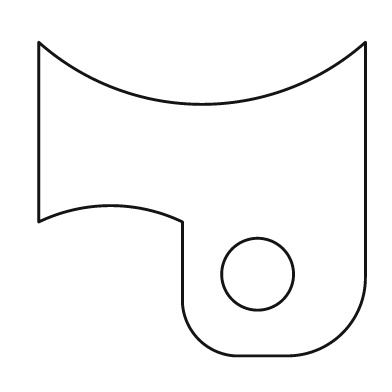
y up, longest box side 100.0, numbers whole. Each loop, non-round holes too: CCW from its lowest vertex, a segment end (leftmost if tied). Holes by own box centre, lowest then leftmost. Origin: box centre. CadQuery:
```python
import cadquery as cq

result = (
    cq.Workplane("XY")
    .moveTo(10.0, -48.0)
    .lineTo(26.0, -48.0)
    .threePointArc((43.0, -41.0), (50.0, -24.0))
    .lineTo(50.0, 48.0)
    .threePointArc((0.0, 29.0), (-50.0, 48.0))
    .lineTo(-50.0, -7.0)
    .threePointArc((-28.0, -2.0), (-6.0, -7.0))
    .lineTo(-6.0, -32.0)
    .threePointArc((-1.0, -43.0), (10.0, -48.0))
    .close()
    .moveTo(17.0, -23.0)
    .circle(11.0)
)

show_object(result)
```